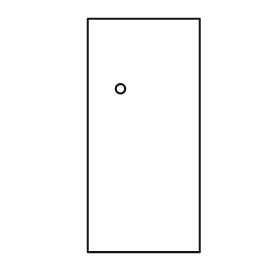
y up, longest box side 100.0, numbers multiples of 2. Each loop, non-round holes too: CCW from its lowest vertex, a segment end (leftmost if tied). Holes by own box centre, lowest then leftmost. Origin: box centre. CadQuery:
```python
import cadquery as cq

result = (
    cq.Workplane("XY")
    .moveTo(-24.0, -50.0)
    .lineTo(24.0, -50.0)
    .lineTo(24.0, 50.0)
    .lineTo(-24.0, 50.0)
    .close()
    .moveTo(-10.0, 20.0)
    .circle(2.0)
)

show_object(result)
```